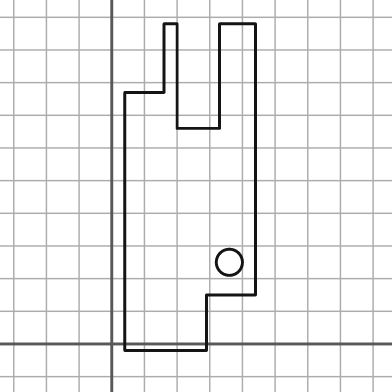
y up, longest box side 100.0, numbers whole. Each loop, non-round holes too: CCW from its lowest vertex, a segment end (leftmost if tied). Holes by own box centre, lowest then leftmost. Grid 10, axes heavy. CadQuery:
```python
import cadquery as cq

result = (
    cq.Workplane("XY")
    .moveTo(4.0, -2.0)
    .lineTo(29.0, -2.0)
    .lineTo(29.0, 15.0)
    .lineTo(44.0, 15.0)
    .lineTo(44.0, 98.0)
    .lineTo(33.0, 98.0)
    .lineTo(33.0, 66.0)
    .lineTo(20.0, 66.0)
    .lineTo(20.0, 98.0)
    .lineTo(16.0, 98.0)
    .lineTo(16.0, 77.0)
    .lineTo(4.0, 77.0)
    .close()
    .moveTo(36.0, 25.0)
    .circle(4.0)
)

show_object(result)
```